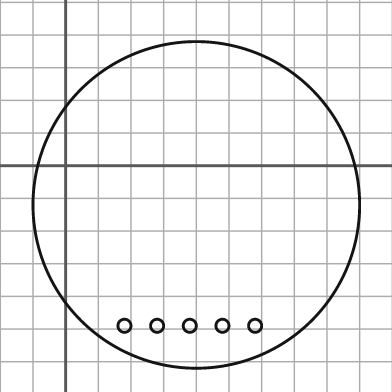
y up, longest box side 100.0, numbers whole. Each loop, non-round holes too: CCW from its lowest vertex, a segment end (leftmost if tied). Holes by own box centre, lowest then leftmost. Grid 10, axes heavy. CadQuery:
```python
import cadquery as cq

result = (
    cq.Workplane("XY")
    .moveTo(40.0, -12.0)
    .circle(50.0)
    .moveTo(18.0, -49.0)
    .circle(2.0)
    .moveTo(28.0, -49.0)
    .circle(2.0)
    .moveTo(38.0, -49.0)
    .circle(2.0)
    .moveTo(48.0, -49.0)
    .circle(2.0)
    .moveTo(58.0, -49.0)
    .circle(2.0)
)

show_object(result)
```